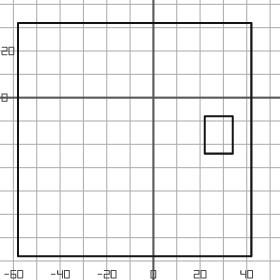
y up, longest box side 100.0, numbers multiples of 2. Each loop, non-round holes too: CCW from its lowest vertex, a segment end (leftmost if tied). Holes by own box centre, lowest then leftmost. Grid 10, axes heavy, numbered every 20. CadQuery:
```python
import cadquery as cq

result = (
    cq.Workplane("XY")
    .moveTo(-58.0, -68.0)
    .lineTo(42.0, -68.0)
    .lineTo(42.0, 32.0)
    .lineTo(-58.0, 32.0)
    .close()
    .moveTo(22.0, -24.0)
    .lineTo(34.0, -24.0)
    .lineTo(34.0, -8.0)
    .lineTo(22.0, -8.0)
    .close()
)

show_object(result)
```